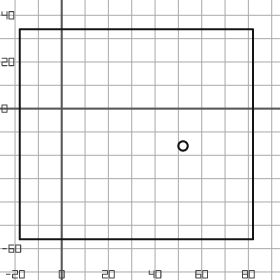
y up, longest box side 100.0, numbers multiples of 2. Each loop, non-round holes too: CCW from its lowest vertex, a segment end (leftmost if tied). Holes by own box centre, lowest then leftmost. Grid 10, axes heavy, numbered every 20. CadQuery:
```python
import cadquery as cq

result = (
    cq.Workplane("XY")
    .moveTo(-18.0, -56.0)
    .lineTo(82.0, -56.0)
    .lineTo(82.0, 34.0)
    .lineTo(-18.0, 34.0)
    .close()
    .moveTo(52.0, -16.0)
    .circle(2.0)
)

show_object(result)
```